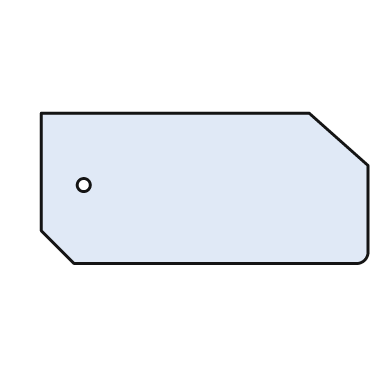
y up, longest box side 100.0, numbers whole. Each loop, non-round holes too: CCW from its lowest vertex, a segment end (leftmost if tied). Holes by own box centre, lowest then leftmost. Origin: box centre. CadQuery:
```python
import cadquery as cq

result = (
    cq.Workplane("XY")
    .moveTo(-40.0, -23.0)
    .lineTo(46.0, -23.0)
    .threePointArc((49.0, -22.0), (50.0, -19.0))
    .lineTo(50.0, 7.0)
    .lineTo(32.0, 23.0)
    .lineTo(-50.0, 23.0)
    .lineTo(-50.0, -13.0)
    .close()
    .moveTo(-37.0, 1.0)
    .circle(2.0)
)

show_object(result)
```